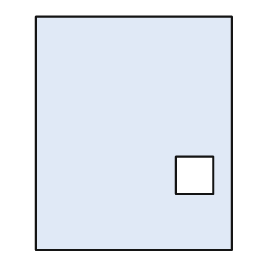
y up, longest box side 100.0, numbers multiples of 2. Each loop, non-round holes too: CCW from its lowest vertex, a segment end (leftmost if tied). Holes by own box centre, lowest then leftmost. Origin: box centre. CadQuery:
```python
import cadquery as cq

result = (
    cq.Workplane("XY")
    .moveTo(-42.0, -50.0)
    .lineTo(42.0, -50.0)
    .lineTo(42.0, 50.0)
    .lineTo(-42.0, 50.0)
    .close()
    .moveTo(18.0, -26.0)
    .lineTo(34.0, -26.0)
    .lineTo(34.0, -10.0)
    .lineTo(18.0, -10.0)
    .close()
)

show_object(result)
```